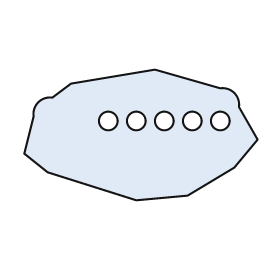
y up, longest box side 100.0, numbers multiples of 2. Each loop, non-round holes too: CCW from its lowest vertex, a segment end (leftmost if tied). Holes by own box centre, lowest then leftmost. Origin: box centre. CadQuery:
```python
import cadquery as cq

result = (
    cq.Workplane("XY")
    .moveTo(-2.0, -28.0)
    .lineTo(20.0, -26.0)
    .lineTo(40.0, -14.0)
    .lineTo(50.0, -2.0)
    .lineTo(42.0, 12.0)
    .threePointArc((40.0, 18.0), (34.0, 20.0))
    .lineTo(6.0, 28.0)
    .lineTo(-30.0, 22.0)
    .lineTo(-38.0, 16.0)
    .threePointArc((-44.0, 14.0), (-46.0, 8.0))
    .lineTo(-50.0, -8.0)
    .lineTo(-40.0, -16.0)
    .close()
    .moveTo(-14.0, 6.0)
    .circle(4.0)
    .moveTo(-2.0, 6.0)
    .circle(4.0)
    .moveTo(10.0, 6.0)
    .circle(4.0)
    .moveTo(22.0, 6.0)
    .circle(4.0)
    .moveTo(34.0, 6.0)
    .circle(4.0)
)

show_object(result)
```